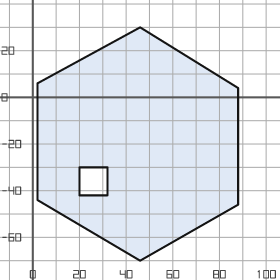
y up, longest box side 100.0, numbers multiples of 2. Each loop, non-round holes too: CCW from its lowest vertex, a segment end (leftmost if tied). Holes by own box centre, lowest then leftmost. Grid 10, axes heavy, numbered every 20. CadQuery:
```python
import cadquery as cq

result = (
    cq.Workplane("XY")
    .moveTo(46.0, -70.0)
    .lineTo(88.0, -46.0)
    .lineTo(88.0, 4.0)
    .lineTo(46.0, 30.0)
    .lineTo(2.0, 6.0)
    .lineTo(2.0, -44.0)
    .close()
    .moveTo(20.0, -42.0)
    .lineTo(32.0, -42.0)
    .lineTo(32.0, -30.0)
    .lineTo(20.0, -30.0)
    .close()
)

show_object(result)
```